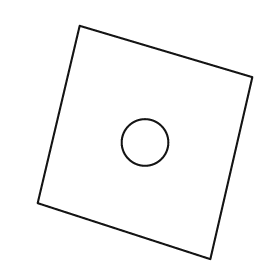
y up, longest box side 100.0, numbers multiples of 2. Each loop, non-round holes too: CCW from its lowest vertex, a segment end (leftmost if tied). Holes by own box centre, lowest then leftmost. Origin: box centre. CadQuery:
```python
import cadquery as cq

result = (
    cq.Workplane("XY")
    .moveTo(28.0, -50.0)
    .lineTo(46.0, 28.0)
    .lineTo(-28.0, 50.0)
    .lineTo(-46.0, -26.0)
    .close()
    .moveTo(0.0, 0.0)
    .circle(10.0)
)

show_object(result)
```